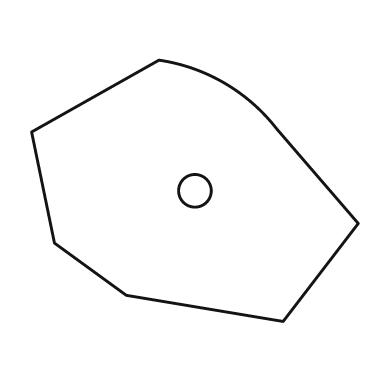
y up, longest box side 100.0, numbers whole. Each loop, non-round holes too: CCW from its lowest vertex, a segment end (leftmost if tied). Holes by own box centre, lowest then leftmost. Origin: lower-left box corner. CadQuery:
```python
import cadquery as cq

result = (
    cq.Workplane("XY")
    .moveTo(77.0, 0.0)
    .lineTo(100.0, 30.0)
    .lineTo(75.0, 59.0)
    .threePointArc((59.0, 73.0), (39.0, 80.0))
    .lineTo(0.0, 58.0)
    .lineTo(7.0, 24.0)
    .lineTo(29.0, 8.0)
    .close()
    .moveTo(50.0, 40.0)
    .circle(5.0)
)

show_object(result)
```